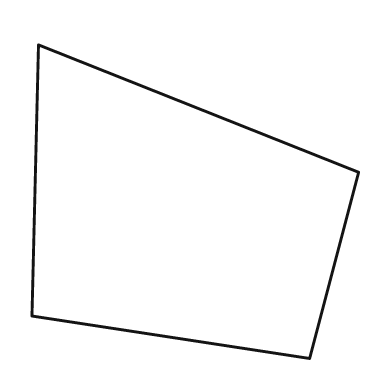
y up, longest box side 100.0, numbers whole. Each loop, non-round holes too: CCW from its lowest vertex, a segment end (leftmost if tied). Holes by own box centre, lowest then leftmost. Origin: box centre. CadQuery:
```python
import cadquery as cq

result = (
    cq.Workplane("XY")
    .moveTo(35.0, -48.0)
    .lineTo(50.0, 9.0)
    .lineTo(-48.0, 48.0)
    .lineTo(-50.0, -35.0)
    .close()
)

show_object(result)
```